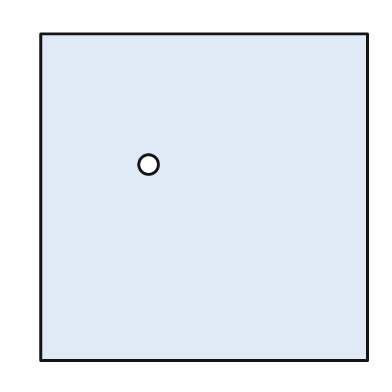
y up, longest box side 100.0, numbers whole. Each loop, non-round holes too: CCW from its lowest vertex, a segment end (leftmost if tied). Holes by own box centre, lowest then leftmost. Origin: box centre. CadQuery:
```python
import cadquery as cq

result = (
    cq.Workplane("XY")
    .moveTo(-50.0, -50.0)
    .lineTo(50.0, -50.0)
    .lineTo(50.0, 50.0)
    .lineTo(-50.0, 50.0)
    .close()
    .moveTo(-17.0, 10.0)
    .circle(3.0)
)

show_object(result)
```